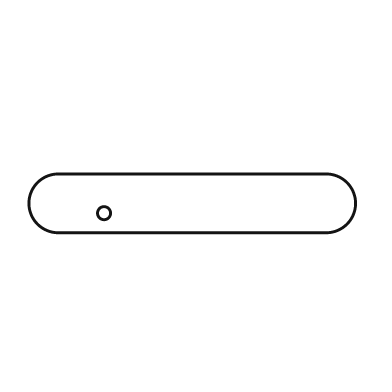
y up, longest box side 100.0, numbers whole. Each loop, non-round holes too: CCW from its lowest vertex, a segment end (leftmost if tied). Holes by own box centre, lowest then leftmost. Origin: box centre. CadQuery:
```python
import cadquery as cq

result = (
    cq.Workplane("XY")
    .moveTo(-41.0, -9.0)
    .lineTo(41.0, -9.0)
    .threePointArc((50.0, 0.0), (41.0, 9.0))
    .lineTo(-41.0, 9.0)
    .threePointArc((-50.0, 0.0), (-41.0, -9.0))
    .close()
    .moveTo(-27.0, -3.0)
    .circle(2.0)
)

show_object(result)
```